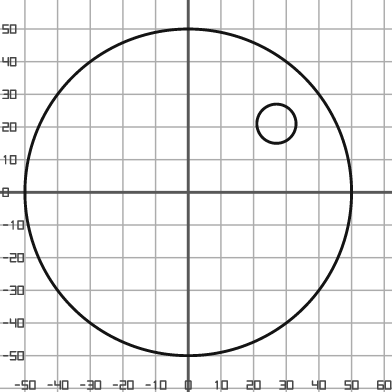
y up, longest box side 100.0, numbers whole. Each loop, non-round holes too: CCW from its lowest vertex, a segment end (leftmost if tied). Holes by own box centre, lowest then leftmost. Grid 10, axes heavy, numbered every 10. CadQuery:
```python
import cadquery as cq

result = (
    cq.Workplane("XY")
    .moveTo(0.0, 0.0)
    .circle(50.0)
    .moveTo(27.0, 21.0)
    .circle(6.0)
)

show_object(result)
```